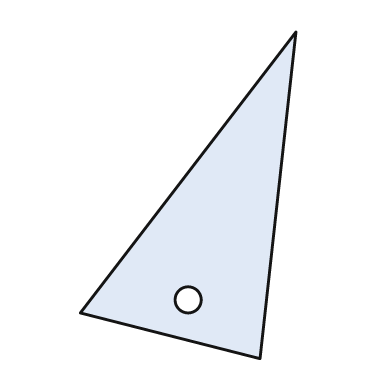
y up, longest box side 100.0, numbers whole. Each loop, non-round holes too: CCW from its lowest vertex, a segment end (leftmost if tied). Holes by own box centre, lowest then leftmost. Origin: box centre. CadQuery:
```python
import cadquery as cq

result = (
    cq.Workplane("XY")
    .moveTo(22.0, -50.0)
    .lineTo(33.0, 50.0)
    .lineTo(-33.0, -36.0)
    .close()
    .moveTo(0.0, -32.0)
    .circle(4.0)
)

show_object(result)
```